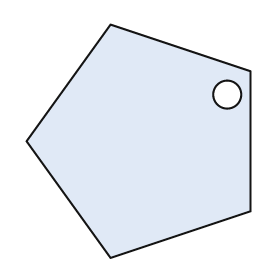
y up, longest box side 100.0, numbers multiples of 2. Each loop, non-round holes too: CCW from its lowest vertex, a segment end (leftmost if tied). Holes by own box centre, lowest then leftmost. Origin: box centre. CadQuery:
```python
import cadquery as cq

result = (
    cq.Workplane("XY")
    .moveTo(-12.0, -50.0)
    .lineTo(48.0, -30.0)
    .lineTo(48.0, 30.0)
    .lineTo(-12.0, 50.0)
    .lineTo(-48.0, 0.0)
    .close()
    .moveTo(38.0, 20.0)
    .circle(6.0)
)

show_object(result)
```